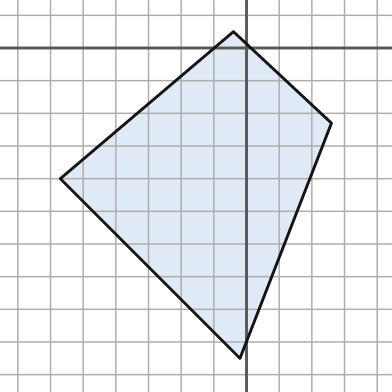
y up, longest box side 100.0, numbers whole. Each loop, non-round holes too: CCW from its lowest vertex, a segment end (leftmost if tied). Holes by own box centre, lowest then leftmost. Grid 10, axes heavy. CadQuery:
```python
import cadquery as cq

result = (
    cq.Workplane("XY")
    .moveTo(-2.0, -95.0)
    .lineTo(26.0, -23.0)
    .lineTo(-4.0, 5.0)
    .lineTo(-57.0, -40.0)
    .close()
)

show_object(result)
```